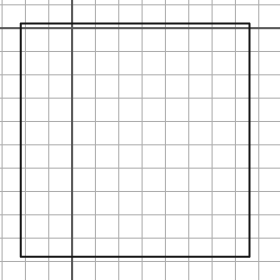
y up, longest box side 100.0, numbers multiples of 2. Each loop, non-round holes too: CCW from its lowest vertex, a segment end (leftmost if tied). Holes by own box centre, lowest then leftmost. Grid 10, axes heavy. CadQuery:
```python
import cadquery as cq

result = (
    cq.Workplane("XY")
    .moveTo(-22.0, -98.0)
    .lineTo(76.0, -98.0)
    .lineTo(76.0, 2.0)
    .lineTo(-22.0, 2.0)
    .close()
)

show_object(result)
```